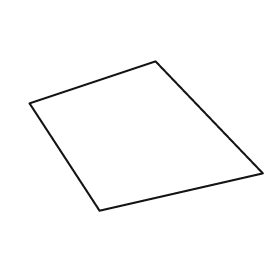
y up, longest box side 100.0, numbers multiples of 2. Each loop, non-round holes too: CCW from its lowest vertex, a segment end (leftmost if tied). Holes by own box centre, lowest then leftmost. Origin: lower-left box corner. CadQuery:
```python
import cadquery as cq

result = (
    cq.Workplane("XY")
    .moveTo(30.0, 0.0)
    .lineTo(100.0, 16.0)
    .lineTo(54.0, 64.0)
    .lineTo(0.0, 46.0)
    .close()
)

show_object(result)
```